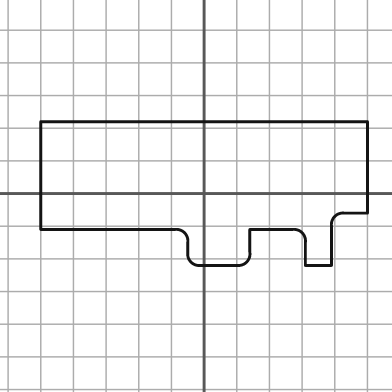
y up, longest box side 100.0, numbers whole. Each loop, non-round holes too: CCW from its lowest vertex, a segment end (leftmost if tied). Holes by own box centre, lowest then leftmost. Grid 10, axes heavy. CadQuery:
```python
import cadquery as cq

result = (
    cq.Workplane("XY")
    .moveTo(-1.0, -22.0)
    .lineTo(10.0, -22.0)
    .threePointArc((13.0, -21.0), (14.0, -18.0))
    .lineTo(14.0, -11.0)
    .lineTo(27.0, -11.0)
    .threePointArc((30.0, -12.0), (31.0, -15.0))
    .lineTo(31.0, -22.0)
    .lineTo(39.0, -22.0)
    .lineTo(39.0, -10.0)
    .threePointArc((40.0, -7.0), (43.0, -6.0))
    .lineTo(50.0, -6.0)
    .lineTo(50.0, 22.0)
    .lineTo(-50.0, 22.0)
    .lineTo(-50.0, -11.0)
    .lineTo(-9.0, -11.0)
    .threePointArc((-6.0, -12.0), (-5.0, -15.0))
    .lineTo(-5.0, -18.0)
    .threePointArc((-4.0, -21.0), (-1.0, -22.0))
    .close()
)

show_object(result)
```